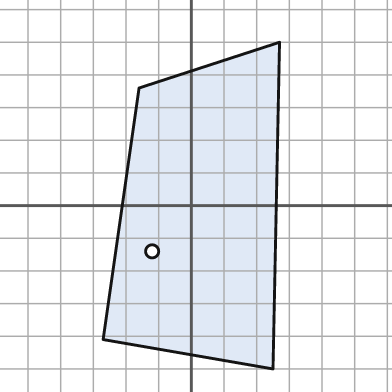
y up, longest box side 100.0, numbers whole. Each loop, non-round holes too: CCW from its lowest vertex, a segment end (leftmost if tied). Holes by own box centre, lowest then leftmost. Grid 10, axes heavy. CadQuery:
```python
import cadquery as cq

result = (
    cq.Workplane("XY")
    .moveTo(25.0, -50.0)
    .lineTo(27.0, 50.0)
    .lineTo(-16.0, 36.0)
    .lineTo(-27.0, -41.0)
    .close()
    .moveTo(-12.0, -14.0)
    .circle(2.0)
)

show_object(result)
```